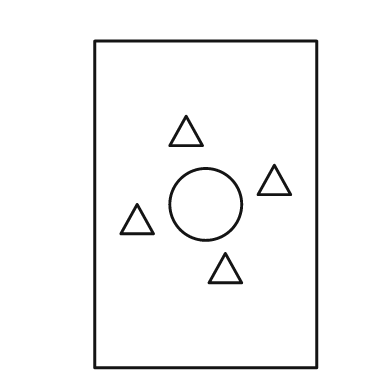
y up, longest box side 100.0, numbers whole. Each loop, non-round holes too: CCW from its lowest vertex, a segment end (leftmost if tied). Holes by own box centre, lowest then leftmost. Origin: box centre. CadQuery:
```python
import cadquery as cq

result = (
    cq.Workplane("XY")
    .moveTo(-34.0, -50.0)
    .lineTo(34.0, -50.0)
    .lineTo(34.0, 50.0)
    .lineTo(-34.0, 50.0)
    .close()
    .moveTo(1.0, -24.0)
    .lineTo(11.0, -24.0)
    .lineTo(6.0, -15.0)
    .close()
    .moveTo(-26.0, -9.0)
    .lineTo(-16.0, -9.0)
    .lineTo(-21.0, 0.0)
    .close()
    .moveTo(0.0, 0.0)
    .circle(11.0)
    .moveTo(16.0, 3.0)
    .lineTo(26.0, 3.0)
    .lineTo(21.0, 12.0)
    .close()
    .moveTo(-11.0, 18.0)
    .lineTo(-1.0, 18.0)
    .lineTo(-6.0, 27.0)
    .close()
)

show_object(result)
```